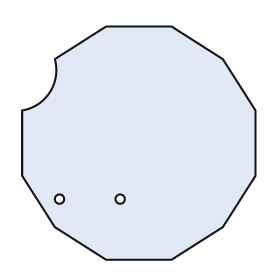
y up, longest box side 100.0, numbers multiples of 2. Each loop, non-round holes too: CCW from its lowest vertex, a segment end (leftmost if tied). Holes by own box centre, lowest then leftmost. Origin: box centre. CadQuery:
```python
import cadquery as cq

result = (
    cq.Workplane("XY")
    .moveTo(-14.0, -50.0)
    .lineTo(14.0, -50.0)
    .lineTo(36.0, -36.0)
    .lineTo(50.0, -14.0)
    .lineTo(50.0, 14.0)
    .lineTo(36.0, 36.0)
    .lineTo(14.0, 50.0)
    .lineTo(-14.0, 50.0)
    .lineTo(-36.0, 36.0)
    .threePointArc((-38.0, 22.0), (-50.0, 14.0))
    .lineTo(-50.0, -14.0)
    .lineTo(-36.0, -36.0)
    .close()
    .moveTo(-34.0, -24.0)
    .circle(2.0)
    .moveTo(-8.0, -24.0)
    .circle(2.0)
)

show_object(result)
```